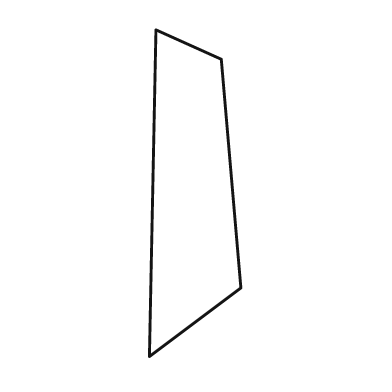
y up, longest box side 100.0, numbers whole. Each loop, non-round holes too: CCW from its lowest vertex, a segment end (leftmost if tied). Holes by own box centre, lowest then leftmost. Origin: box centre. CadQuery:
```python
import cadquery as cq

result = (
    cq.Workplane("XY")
    .moveTo(-14.0, -50.0)
    .lineTo(14.0, -29.0)
    .lineTo(8.0, 41.0)
    .lineTo(-12.0, 50.0)
    .close()
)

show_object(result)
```